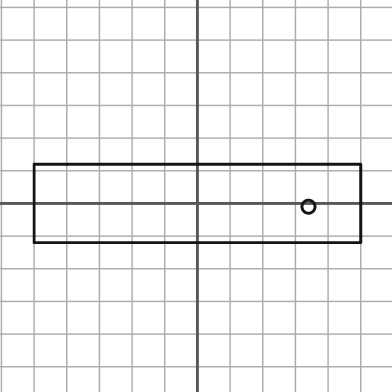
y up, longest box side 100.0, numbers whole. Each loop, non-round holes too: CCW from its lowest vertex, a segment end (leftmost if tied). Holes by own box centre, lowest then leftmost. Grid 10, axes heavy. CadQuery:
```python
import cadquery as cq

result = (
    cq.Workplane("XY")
    .moveTo(-50.0, -12.0)
    .lineTo(50.0, -12.0)
    .lineTo(50.0, 12.0)
    .lineTo(-50.0, 12.0)
    .close()
    .moveTo(34.0, -1.0)
    .circle(2.0)
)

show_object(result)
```